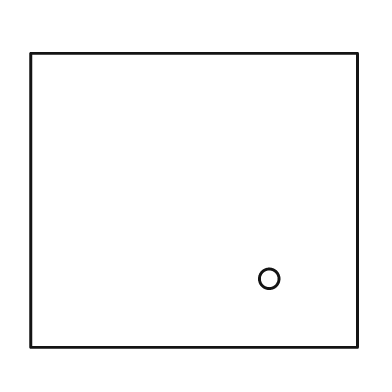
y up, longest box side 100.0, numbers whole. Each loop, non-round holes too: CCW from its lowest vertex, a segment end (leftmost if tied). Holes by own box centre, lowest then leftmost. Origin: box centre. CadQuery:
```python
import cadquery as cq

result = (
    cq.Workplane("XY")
    .moveTo(-50.0, -45.0)
    .lineTo(50.0, -45.0)
    .lineTo(50.0, 45.0)
    .lineTo(-50.0, 45.0)
    .close()
    .moveTo(23.0, -24.0)
    .circle(3.0)
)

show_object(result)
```